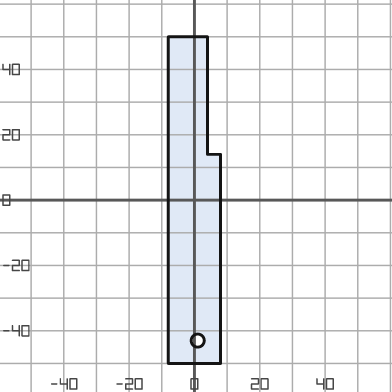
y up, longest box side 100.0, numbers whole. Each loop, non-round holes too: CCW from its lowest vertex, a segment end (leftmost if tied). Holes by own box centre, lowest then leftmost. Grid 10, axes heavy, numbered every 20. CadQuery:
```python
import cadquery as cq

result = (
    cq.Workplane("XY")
    .moveTo(-8.0, -50.0)
    .lineTo(8.0, -50.0)
    .lineTo(8.0, 14.0)
    .lineTo(4.0, 14.0)
    .lineTo(4.0, 50.0)
    .lineTo(-8.0, 50.0)
    .close()
    .moveTo(1.0, -43.0)
    .circle(2.0)
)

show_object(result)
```